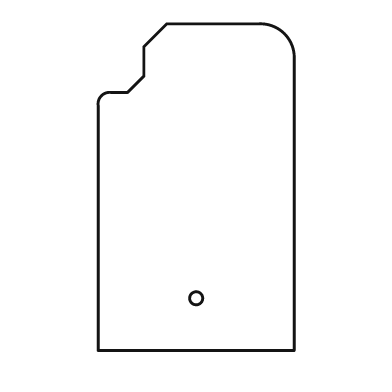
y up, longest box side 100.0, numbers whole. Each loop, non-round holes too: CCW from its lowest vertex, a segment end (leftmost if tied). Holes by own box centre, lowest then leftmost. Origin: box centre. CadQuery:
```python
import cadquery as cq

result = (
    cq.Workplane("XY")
    .moveTo(-30.0, -50.0)
    .lineTo(30.0, -50.0)
    .lineTo(30.0, 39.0)
    .threePointArc((27.0, 47.0), (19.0, 50.0))
    .lineTo(-9.0, 50.0)
    .lineTo(-16.0, 43.0)
    .lineTo(-16.0, 34.0)
    .lineTo(-21.0, 29.0)
    .lineTo(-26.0, 29.0)
    .threePointArc((-29.0, 28.0), (-30.0, 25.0))
    .close()
    .moveTo(0.0, -34.0)
    .circle(2.0)
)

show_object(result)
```